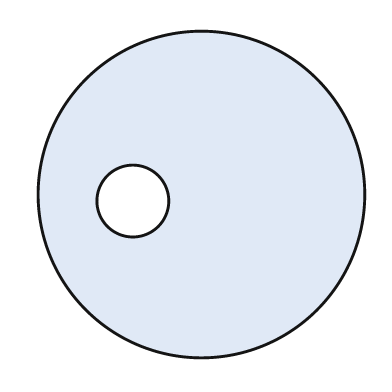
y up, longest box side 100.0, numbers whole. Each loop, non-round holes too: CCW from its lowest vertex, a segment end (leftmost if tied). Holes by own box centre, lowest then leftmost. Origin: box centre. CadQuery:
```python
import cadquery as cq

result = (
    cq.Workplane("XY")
    .moveTo(0.0, 0.0)
    .circle(50.0)
    .moveTo(-21.0, -2.0)
    .circle(11.0)
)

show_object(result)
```